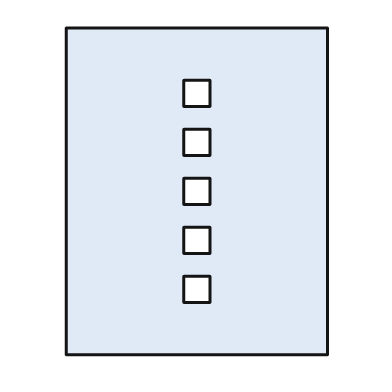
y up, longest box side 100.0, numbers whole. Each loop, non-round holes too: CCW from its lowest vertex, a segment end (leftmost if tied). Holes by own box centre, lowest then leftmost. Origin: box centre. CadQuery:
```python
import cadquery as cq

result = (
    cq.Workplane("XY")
    .moveTo(-40.0, -50.0)
    .lineTo(40.0, -50.0)
    .lineTo(40.0, 50.0)
    .lineTo(-40.0, 50.0)
    .close()
    .moveTo(-4.0, -34.0)
    .lineTo(4.0, -34.0)
    .lineTo(4.0, -26.0)
    .lineTo(-4.0, -26.0)
    .close()
    .moveTo(-4.0, -19.0)
    .lineTo(4.0, -19.0)
    .lineTo(4.0, -11.0)
    .lineTo(-4.0, -11.0)
    .close()
    .moveTo(-4.0, -4.0)
    .lineTo(4.0, -4.0)
    .lineTo(4.0, 4.0)
    .lineTo(-4.0, 4.0)
    .close()
    .moveTo(-4.0, 11.0)
    .lineTo(4.0, 11.0)
    .lineTo(4.0, 19.0)
    .lineTo(-4.0, 19.0)
    .close()
    .moveTo(-4.0, 26.0)
    .lineTo(4.0, 26.0)
    .lineTo(4.0, 34.0)
    .lineTo(-4.0, 34.0)
    .close()
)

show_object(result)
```